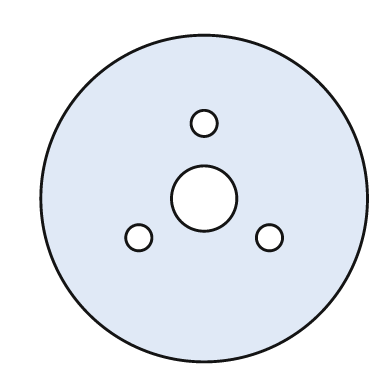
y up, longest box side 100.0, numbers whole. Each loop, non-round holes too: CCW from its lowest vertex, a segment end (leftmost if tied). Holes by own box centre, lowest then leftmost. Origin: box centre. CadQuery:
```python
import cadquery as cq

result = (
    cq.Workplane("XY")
    .moveTo(0.0, 0.0)
    .circle(50.0)
    .moveTo(-20.0, -12.0)
    .circle(4.0)
    .moveTo(20.0, -12.0)
    .circle(4.0)
    .moveTo(0.0, 0.0)
    .circle(10.0)
    .moveTo(0.0, 23.0)
    .circle(4.0)
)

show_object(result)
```